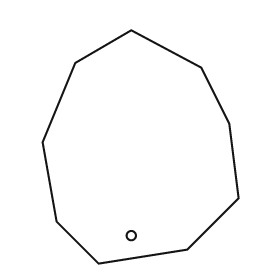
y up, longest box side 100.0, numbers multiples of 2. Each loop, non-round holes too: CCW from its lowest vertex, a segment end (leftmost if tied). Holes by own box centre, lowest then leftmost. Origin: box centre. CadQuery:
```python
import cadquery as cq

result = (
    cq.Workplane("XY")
    .moveTo(-18.0, -50.0)
    .lineTo(20.0, -44.0)
    .lineTo(42.0, -22.0)
    .lineTo(38.0, 10.0)
    .lineTo(26.0, 34.0)
    .lineTo(-4.0, 50.0)
    .lineTo(-28.0, 36.0)
    .lineTo(-42.0, 2.0)
    .lineTo(-36.0, -32.0)
    .close()
    .moveTo(-4.0, -38.0)
    .circle(2.0)
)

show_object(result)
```